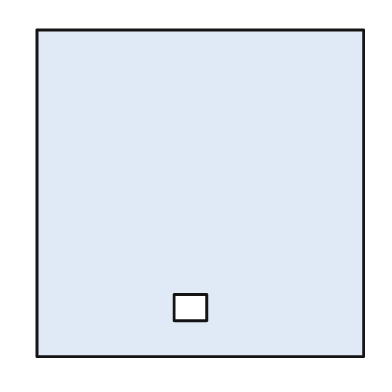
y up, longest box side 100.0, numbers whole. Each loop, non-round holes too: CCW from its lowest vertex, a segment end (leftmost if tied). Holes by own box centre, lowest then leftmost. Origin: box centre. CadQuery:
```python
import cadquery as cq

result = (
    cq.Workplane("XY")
    .moveTo(-50.0, -50.0)
    .lineTo(50.0, -50.0)
    .lineTo(50.0, 50.0)
    .lineTo(-50.0, 50.0)
    .close()
    .moveTo(-8.0, -39.0)
    .lineTo(2.0, -39.0)
    .lineTo(2.0, -31.0)
    .lineTo(-8.0, -31.0)
    .close()
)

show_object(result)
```